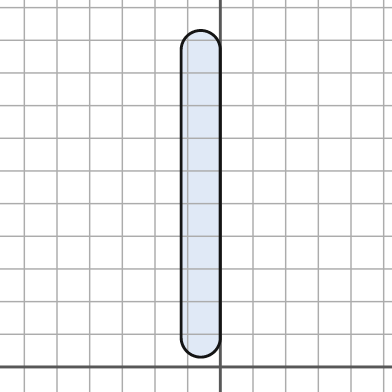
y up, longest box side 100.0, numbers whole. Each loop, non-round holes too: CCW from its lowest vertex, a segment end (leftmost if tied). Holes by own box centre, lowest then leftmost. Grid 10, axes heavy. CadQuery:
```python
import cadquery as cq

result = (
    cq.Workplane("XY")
    .moveTo(-12.0, 9.0)
    .threePointArc((-6.0, 3.0), (0.0, 9.0))
    .lineTo(0.0, 97.0)
    .threePointArc((-6.0, 103.0), (-12.0, 97.0))
    .close()
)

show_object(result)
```